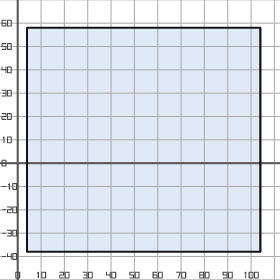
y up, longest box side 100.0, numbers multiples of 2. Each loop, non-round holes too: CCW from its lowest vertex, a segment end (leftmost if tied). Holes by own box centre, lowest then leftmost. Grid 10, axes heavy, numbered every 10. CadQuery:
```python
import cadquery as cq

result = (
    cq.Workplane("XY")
    .moveTo(4.0, -38.0)
    .lineTo(104.0, -38.0)
    .lineTo(104.0, 58.0)
    .lineTo(4.0, 58.0)
    .close()
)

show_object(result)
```